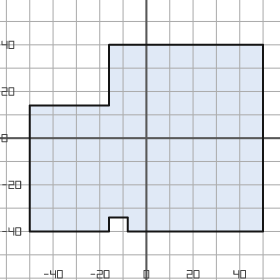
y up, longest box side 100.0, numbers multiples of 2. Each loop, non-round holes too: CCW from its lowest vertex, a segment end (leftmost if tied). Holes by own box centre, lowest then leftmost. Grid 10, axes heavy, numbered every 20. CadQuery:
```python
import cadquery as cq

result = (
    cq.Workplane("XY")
    .moveTo(-50.0, -40.0)
    .lineTo(-16.0, -40.0)
    .lineTo(-16.0, -34.0)
    .lineTo(-8.0, -34.0)
    .lineTo(-8.0, -40.0)
    .lineTo(50.0, -40.0)
    .lineTo(50.0, 40.0)
    .lineTo(-16.0, 40.0)
    .lineTo(-16.0, 14.0)
    .lineTo(-50.0, 14.0)
    .close()
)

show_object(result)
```